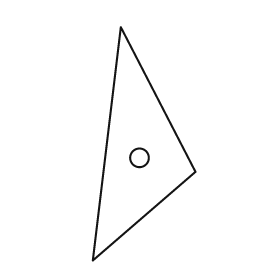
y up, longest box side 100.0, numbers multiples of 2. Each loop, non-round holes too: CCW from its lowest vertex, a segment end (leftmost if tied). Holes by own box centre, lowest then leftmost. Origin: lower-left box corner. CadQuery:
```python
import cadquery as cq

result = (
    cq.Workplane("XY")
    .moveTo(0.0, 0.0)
    .lineTo(44.0, 38.0)
    .lineTo(12.0, 100.0)
    .close()
    .moveTo(20.0, 44.0)
    .circle(4.0)
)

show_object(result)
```